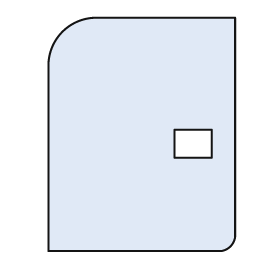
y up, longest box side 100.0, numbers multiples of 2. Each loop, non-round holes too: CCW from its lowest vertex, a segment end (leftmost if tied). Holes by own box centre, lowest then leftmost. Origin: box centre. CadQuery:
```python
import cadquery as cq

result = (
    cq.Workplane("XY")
    .moveTo(-40.0, -50.0)
    .lineTo(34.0, -50.0)
    .threePointArc((38.0, -48.0), (40.0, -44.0))
    .lineTo(40.0, 50.0)
    .lineTo(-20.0, 50.0)
    .threePointArc((-34.0, 44.0), (-40.0, 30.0))
    .close()
    .moveTo(14.0, -10.0)
    .lineTo(30.0, -10.0)
    .lineTo(30.0, 2.0)
    .lineTo(14.0, 2.0)
    .close()
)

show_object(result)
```